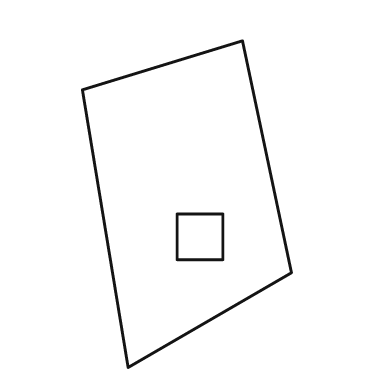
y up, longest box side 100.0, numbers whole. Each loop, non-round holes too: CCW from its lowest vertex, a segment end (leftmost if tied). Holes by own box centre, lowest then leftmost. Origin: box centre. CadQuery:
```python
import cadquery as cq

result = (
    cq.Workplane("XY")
    .moveTo(-18.0, -50.0)
    .lineTo(32.0, -21.0)
    .lineTo(17.0, 50.0)
    .lineTo(-32.0, 35.0)
    .close()
    .moveTo(-3.0, -17.0)
    .lineTo(11.0, -17.0)
    .lineTo(11.0, -3.0)
    .lineTo(-3.0, -3.0)
    .close()
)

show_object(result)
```